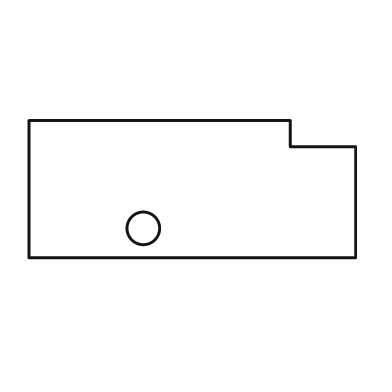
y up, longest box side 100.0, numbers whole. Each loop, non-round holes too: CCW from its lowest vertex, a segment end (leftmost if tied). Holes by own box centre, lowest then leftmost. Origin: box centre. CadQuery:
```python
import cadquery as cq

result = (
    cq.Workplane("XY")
    .moveTo(-50.0, -21.0)
    .lineTo(50.0, -21.0)
    .lineTo(50.0, 13.0)
    .lineTo(30.0, 13.0)
    .lineTo(30.0, 21.0)
    .lineTo(-50.0, 21.0)
    .close()
    .moveTo(-15.0, -12.0)
    .circle(5.0)
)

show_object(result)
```